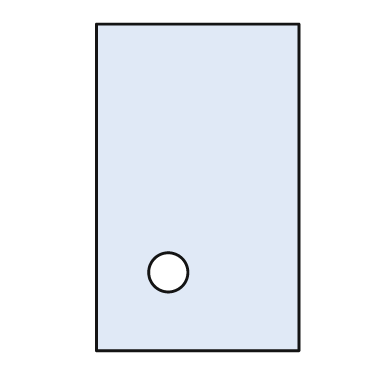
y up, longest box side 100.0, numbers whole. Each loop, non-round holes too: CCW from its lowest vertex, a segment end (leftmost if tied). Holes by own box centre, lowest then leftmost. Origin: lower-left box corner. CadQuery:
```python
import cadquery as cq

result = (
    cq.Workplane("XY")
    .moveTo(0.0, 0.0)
    .lineTo(62.0, 0.0)
    .lineTo(62.0, 100.0)
    .lineTo(0.0, 100.0)
    .close()
    .moveTo(22.0, 24.0)
    .circle(6.0)
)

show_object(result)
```